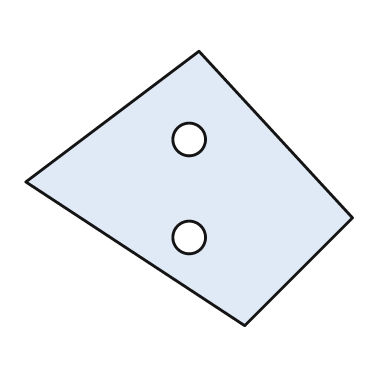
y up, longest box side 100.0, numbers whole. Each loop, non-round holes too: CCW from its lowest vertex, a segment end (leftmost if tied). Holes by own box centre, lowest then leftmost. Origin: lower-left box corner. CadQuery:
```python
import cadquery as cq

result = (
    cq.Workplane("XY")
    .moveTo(67.0, 0.0)
    .lineTo(100.0, 33.0)
    .lineTo(53.0, 84.0)
    .lineTo(0.0, 44.0)
    .close()
    .moveTo(50.0, 27.0)
    .circle(5.0)
    .moveTo(50.0, 57.0)
    .circle(5.0)
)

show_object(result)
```